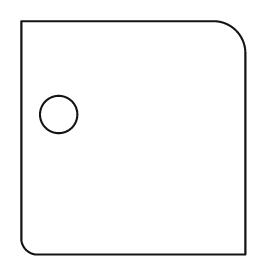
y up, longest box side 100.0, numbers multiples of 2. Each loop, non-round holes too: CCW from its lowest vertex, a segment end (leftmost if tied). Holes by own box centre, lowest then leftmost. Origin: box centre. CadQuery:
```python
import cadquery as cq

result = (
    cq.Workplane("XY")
    .moveTo(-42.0, -50.0)
    .lineTo(48.0, -50.0)
    .lineTo(48.0, 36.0)
    .threePointArc((44.0, 46.0), (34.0, 50.0))
    .lineTo(-48.0, 50.0)
    .lineTo(-48.0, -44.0)
    .threePointArc((-46.0, -48.0), (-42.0, -50.0))
    .close()
    .moveTo(-32.0, 10.0)
    .circle(8.0)
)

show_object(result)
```